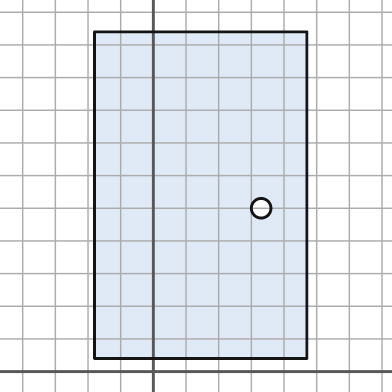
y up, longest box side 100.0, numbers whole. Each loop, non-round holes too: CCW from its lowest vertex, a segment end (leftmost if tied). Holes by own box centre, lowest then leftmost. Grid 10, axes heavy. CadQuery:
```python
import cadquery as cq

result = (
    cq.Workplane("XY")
    .moveTo(-18.0, 4.0)
    .lineTo(47.0, 4.0)
    .lineTo(47.0, 104.0)
    .lineTo(-18.0, 104.0)
    .close()
    .moveTo(33.0, 50.0)
    .circle(3.0)
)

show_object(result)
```